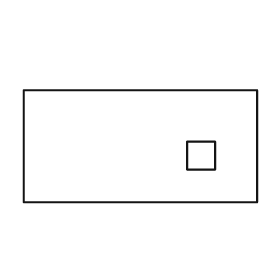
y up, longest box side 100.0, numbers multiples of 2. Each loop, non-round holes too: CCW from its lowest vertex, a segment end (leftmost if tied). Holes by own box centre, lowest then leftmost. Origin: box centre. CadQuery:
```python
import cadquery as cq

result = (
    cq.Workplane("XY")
    .moveTo(-50.0, -24.0)
    .lineTo(50.0, -24.0)
    .lineTo(50.0, 24.0)
    .lineTo(-50.0, 24.0)
    .close()
    .moveTo(20.0, -10.0)
    .lineTo(32.0, -10.0)
    .lineTo(32.0, 2.0)
    .lineTo(20.0, 2.0)
    .close()
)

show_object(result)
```